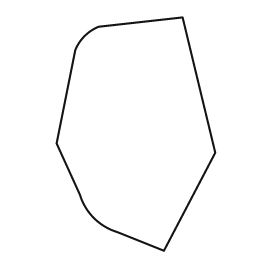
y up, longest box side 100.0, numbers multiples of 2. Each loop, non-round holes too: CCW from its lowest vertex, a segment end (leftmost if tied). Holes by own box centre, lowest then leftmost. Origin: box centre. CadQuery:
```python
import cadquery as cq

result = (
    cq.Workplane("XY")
    .moveTo(12.0, -50.0)
    .lineTo(34.0, -8.0)
    .lineTo(20.0, 50.0)
    .lineTo(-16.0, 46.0)
    .threePointArc((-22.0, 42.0), (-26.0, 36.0))
    .lineTo(-34.0, -4.0)
    .lineTo(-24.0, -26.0)
    .threePointArc((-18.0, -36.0), (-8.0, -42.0))
    .close()
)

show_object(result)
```